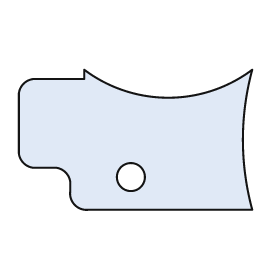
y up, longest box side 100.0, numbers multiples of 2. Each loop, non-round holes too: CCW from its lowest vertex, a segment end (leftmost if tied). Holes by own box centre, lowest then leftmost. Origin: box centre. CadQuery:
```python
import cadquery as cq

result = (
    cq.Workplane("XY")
    .moveTo(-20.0, -30.0)
    .lineTo(50.0, -30.0)
    .threePointArc((46.0, 0.0), (50.0, 30.0))
    .threePointArc((14.0, 18.0), (-22.0, 30.0))
    .lineTo(-22.0, 26.0)
    .lineTo(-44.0, 26.0)
    .threePointArc((-48.0, 24.0), (-50.0, 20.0))
    .lineTo(-50.0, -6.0)
    .threePointArc((-48.0, -10.0), (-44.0, -12.0))
    .lineTo(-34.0, -12.0)
    .threePointArc((-30.0, -14.0), (-28.0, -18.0))
    .lineTo(-28.0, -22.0)
    .threePointArc((-26.0, -28.0), (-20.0, -30.0))
    .close()
    .moveTo(-2.0, -16.0)
    .circle(6.0)
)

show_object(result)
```